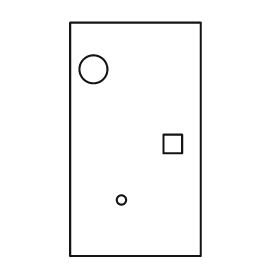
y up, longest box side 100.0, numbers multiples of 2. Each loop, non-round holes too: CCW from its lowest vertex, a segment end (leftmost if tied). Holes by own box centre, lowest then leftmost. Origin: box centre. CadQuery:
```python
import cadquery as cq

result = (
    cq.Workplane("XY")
    .moveTo(-28.0, -50.0)
    .lineTo(28.0, -50.0)
    .lineTo(28.0, 50.0)
    .lineTo(-28.0, 50.0)
    .close()
    .moveTo(-6.0, -26.0)
    .circle(2.0)
    .moveTo(12.0, -6.0)
    .lineTo(20.0, -6.0)
    .lineTo(20.0, 2.0)
    .lineTo(12.0, 2.0)
    .close()
    .moveTo(-18.0, 30.0)
    .circle(6.0)
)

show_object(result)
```